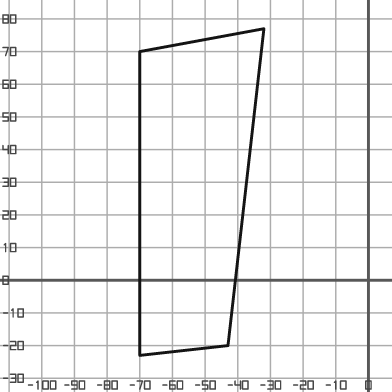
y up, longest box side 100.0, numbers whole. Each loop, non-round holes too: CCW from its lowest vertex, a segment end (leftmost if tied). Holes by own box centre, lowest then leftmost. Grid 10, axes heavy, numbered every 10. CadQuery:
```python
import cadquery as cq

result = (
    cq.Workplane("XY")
    .moveTo(-70.0, -23.0)
    .lineTo(-43.0, -20.0)
    .lineTo(-32.0, 77.0)
    .lineTo(-70.0, 70.0)
    .close()
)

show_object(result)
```